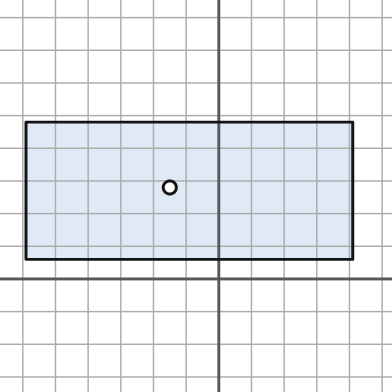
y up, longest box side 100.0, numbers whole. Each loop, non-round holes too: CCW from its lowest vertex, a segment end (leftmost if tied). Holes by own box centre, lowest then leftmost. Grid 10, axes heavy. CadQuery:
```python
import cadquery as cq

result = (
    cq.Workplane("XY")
    .moveTo(-59.0, 6.0)
    .lineTo(41.0, 6.0)
    .lineTo(41.0, 48.0)
    .lineTo(-59.0, 48.0)
    .close()
    .moveTo(-15.0, 28.0)
    .circle(2.0)
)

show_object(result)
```